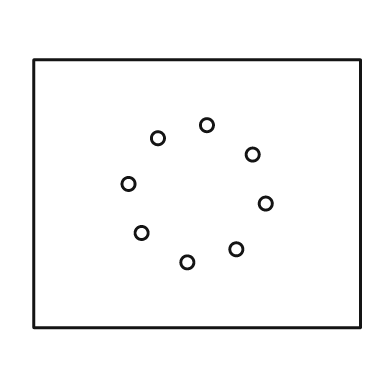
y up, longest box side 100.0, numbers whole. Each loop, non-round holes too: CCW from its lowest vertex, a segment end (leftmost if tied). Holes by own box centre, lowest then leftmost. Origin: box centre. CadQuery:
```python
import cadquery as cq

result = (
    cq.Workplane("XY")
    .moveTo(-50.0, -41.0)
    .lineTo(50.0, -41.0)
    .lineTo(50.0, 41.0)
    .lineTo(-50.0, 41.0)
    .close()
    .moveTo(-3.0, -21.0)
    .circle(2.0)
    .moveTo(12.0, -17.0)
    .circle(2.0)
    .moveTo(-17.0, -12.0)
    .circle(2.0)
    .moveTo(21.0, -3.0)
    .circle(2.0)
    .moveTo(-21.0, 3.0)
    .circle(2.0)
    .moveTo(17.0, 12.0)
    .circle(2.0)
    .moveTo(-12.0, 17.0)
    .circle(2.0)
    .moveTo(3.0, 21.0)
    .circle(2.0)
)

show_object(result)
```